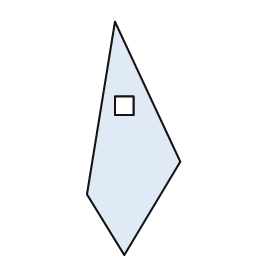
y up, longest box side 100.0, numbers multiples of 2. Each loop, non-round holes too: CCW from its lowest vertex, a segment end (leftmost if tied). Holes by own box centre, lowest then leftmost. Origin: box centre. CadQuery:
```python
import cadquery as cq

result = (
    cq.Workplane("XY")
    .moveTo(-4.0, -50.0)
    .lineTo(20.0, -10.0)
    .lineTo(-8.0, 50.0)
    .lineTo(-20.0, -24.0)
    .close()
    .moveTo(-8.0, 10.0)
    .lineTo(0.0, 10.0)
    .lineTo(0.0, 18.0)
    .lineTo(-8.0, 18.0)
    .close()
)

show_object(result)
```